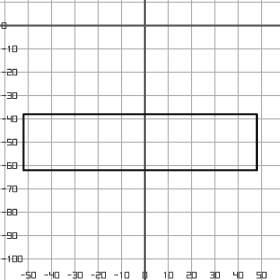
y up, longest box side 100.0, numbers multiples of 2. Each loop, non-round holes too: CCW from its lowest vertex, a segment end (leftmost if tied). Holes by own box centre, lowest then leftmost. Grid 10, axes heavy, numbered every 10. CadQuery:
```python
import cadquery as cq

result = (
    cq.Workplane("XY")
    .moveTo(-52.0, -62.0)
    .lineTo(48.0, -62.0)
    .lineTo(48.0, -38.0)
    .lineTo(-52.0, -38.0)
    .close()
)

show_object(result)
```